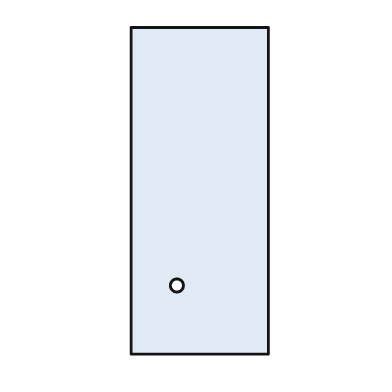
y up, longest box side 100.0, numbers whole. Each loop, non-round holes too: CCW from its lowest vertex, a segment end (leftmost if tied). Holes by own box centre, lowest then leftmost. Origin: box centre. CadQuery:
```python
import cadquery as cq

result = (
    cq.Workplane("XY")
    .moveTo(-21.0, -50.0)
    .lineTo(21.0, -50.0)
    .lineTo(21.0, 50.0)
    .lineTo(-21.0, 50.0)
    .close()
    .moveTo(-7.0, -29.0)
    .circle(2.0)
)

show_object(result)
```